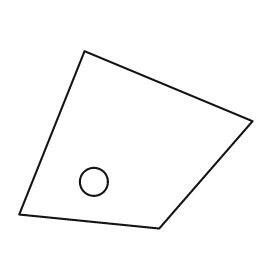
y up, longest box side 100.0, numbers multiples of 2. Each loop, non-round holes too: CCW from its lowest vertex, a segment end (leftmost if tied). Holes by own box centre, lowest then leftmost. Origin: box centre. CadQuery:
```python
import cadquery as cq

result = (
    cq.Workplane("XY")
    .moveTo(10.0, -38.0)
    .lineTo(50.0, 8.0)
    .lineTo(-22.0, 38.0)
    .lineTo(-50.0, -32.0)
    .close()
    .moveTo(-18.0, -18.0)
    .circle(6.0)
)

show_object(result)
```